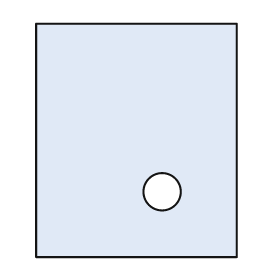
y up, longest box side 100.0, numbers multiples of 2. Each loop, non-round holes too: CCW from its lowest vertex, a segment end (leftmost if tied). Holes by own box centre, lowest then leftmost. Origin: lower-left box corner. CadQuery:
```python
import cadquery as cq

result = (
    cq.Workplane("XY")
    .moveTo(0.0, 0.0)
    .lineTo(86.0, 0.0)
    .lineTo(86.0, 100.0)
    .lineTo(0.0, 100.0)
    .close()
    .moveTo(54.0, 28.0)
    .circle(8.0)
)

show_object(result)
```